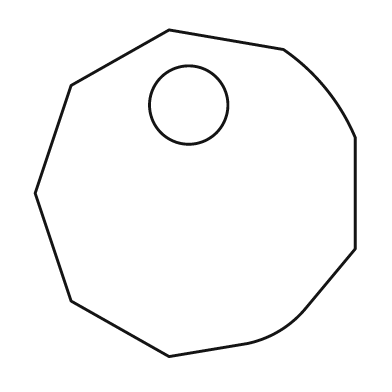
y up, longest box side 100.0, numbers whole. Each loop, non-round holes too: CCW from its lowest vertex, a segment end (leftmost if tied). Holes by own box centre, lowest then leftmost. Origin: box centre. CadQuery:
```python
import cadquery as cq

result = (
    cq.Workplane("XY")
    .moveTo(-8.0, -50.0)
    .lineTo(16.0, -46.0)
    .threePointArc((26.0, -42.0), (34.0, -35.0))
    .lineTo(49.0, -17.0)
    .lineTo(49.0, 17.0)
    .threePointArc((40.0, 32.0), (27.0, 44.0))
    .lineTo(-8.0, 50.0)
    .lineTo(-38.0, 33.0)
    .lineTo(-49.0, 0.0)
    .lineTo(-38.0, -33.0)
    .close()
    .moveTo(-2.0, 27.0)
    .circle(12.0)
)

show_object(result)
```